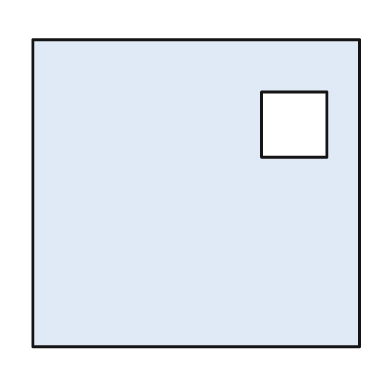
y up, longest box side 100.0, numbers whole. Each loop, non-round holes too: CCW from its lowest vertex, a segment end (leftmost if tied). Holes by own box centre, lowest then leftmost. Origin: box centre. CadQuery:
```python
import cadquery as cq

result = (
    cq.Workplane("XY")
    .moveTo(-50.0, -47.0)
    .lineTo(50.0, -47.0)
    .lineTo(50.0, 47.0)
    .lineTo(-50.0, 47.0)
    .close()
    .moveTo(20.0, 11.0)
    .lineTo(40.0, 11.0)
    .lineTo(40.0, 31.0)
    .lineTo(20.0, 31.0)
    .close()
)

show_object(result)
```